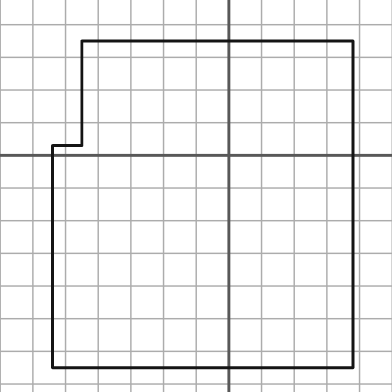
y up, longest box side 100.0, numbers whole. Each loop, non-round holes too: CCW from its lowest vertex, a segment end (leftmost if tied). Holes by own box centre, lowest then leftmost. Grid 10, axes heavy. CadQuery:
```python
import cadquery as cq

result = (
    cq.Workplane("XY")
    .moveTo(-54.0, -65.0)
    .lineTo(38.0, -65.0)
    .lineTo(38.0, 35.0)
    .lineTo(-45.0, 35.0)
    .lineTo(-45.0, 3.0)
    .lineTo(-54.0, 3.0)
    .close()
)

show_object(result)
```